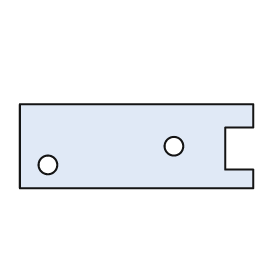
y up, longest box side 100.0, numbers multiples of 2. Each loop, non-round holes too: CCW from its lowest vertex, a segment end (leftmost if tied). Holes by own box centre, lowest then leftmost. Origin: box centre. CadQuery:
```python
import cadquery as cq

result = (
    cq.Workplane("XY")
    .moveTo(-50.0, -18.0)
    .lineTo(50.0, -18.0)
    .lineTo(50.0, -10.0)
    .lineTo(38.0, -10.0)
    .lineTo(38.0, 8.0)
    .lineTo(50.0, 8.0)
    .lineTo(50.0, 18.0)
    .lineTo(-50.0, 18.0)
    .close()
    .moveTo(-38.0, -8.0)
    .circle(4.0)
    .moveTo(16.0, 0.0)
    .circle(4.0)
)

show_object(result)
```